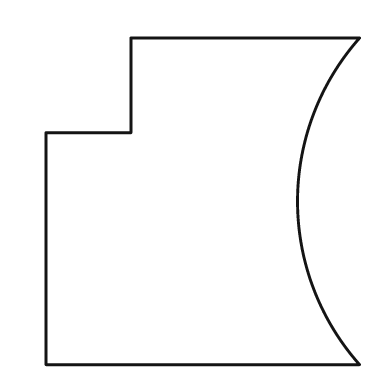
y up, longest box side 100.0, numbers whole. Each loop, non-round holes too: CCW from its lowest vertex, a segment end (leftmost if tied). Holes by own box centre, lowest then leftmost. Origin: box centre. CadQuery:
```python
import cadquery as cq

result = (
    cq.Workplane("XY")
    .moveTo(-48.0, -50.0)
    .lineTo(48.0, -50.0)
    .threePointArc((29.0, 0.0), (48.0, 50.0))
    .lineTo(-22.0, 50.0)
    .lineTo(-22.0, 21.0)
    .lineTo(-48.0, 21.0)
    .close()
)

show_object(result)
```